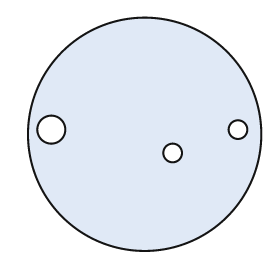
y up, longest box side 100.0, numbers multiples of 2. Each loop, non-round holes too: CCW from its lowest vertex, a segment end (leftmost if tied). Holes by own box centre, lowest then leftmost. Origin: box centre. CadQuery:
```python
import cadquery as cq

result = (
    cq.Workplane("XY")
    .moveTo(0.0, 0.0)
    .circle(50.0)
    .moveTo(12.0, -8.0)
    .circle(4.0)
    .moveTo(-40.0, 2.0)
    .circle(6.0)
    .moveTo(40.0, 2.0)
    .circle(4.0)
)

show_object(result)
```